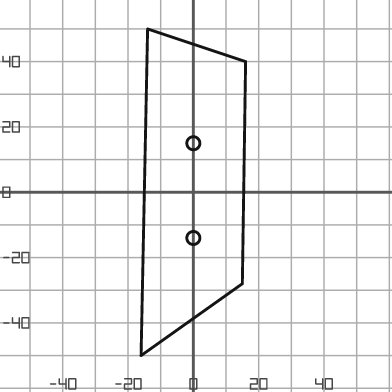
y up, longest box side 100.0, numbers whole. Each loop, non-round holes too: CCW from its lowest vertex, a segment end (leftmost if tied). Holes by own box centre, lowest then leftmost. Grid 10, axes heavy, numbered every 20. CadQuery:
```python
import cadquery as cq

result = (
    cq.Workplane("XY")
    .moveTo(-16.0, -50.0)
    .lineTo(15.0, -28.0)
    .lineTo(16.0, 40.0)
    .lineTo(-14.0, 50.0)
    .close()
    .moveTo(0.0, -14.0)
    .circle(2.0)
    .moveTo(0.0, 15.0)
    .circle(2.0)
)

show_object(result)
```